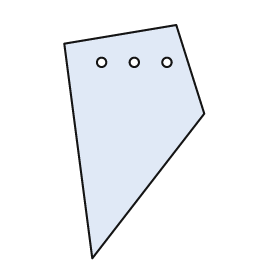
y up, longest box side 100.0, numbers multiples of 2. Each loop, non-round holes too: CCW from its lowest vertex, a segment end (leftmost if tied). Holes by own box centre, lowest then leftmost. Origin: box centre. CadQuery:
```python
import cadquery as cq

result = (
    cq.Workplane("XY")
    .moveTo(-18.0, -50.0)
    .lineTo(30.0, 12.0)
    .lineTo(18.0, 50.0)
    .lineTo(-30.0, 42.0)
    .close()
    .moveTo(-14.0, 34.0)
    .circle(2.0)
    .moveTo(0.0, 34.0)
    .circle(2.0)
    .moveTo(14.0, 34.0)
    .circle(2.0)
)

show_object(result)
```